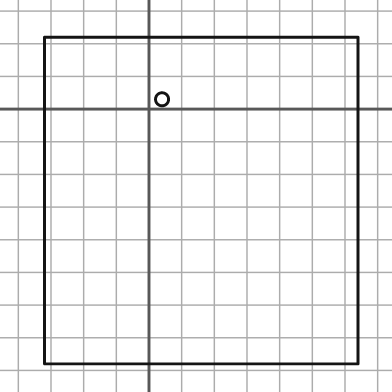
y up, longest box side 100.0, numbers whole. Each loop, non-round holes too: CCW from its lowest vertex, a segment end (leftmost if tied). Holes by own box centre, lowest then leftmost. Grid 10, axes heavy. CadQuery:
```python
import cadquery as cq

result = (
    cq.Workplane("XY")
    .moveTo(-32.0, -78.0)
    .lineTo(64.0, -78.0)
    .lineTo(64.0, 22.0)
    .lineTo(-32.0, 22.0)
    .close()
    .moveTo(4.0, 3.0)
    .circle(2.0)
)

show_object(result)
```